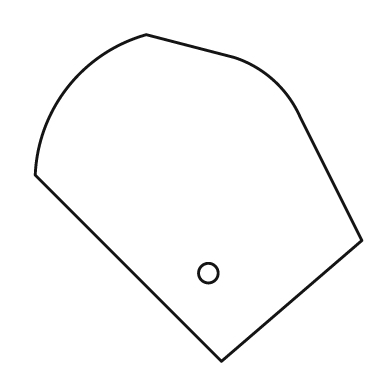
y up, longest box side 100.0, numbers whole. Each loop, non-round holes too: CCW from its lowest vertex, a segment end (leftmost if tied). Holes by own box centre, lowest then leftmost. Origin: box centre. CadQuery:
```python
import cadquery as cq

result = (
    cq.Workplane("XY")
    .moveTo(7.0, -50.0)
    .lineTo(50.0, -13.0)
    .lineTo(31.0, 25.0)
    .threePointArc((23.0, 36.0), (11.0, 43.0))
    .lineTo(-16.0, 50.0)
    .threePointArc((-40.0, 34.0), (-50.0, 7.0))
    .close()
    .moveTo(3.0, -23.0)
    .circle(3.0)
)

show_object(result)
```